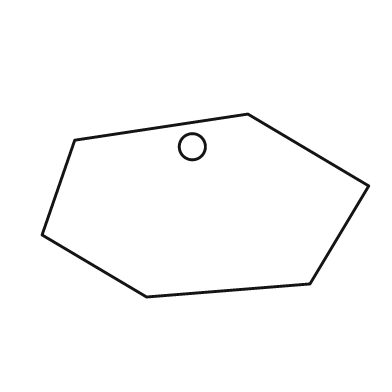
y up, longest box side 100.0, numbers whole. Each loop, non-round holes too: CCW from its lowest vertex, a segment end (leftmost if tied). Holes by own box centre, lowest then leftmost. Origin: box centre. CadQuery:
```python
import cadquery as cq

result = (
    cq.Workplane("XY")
    .moveTo(-18.0, -28.0)
    .lineTo(32.0, -24.0)
    .lineTo(50.0, 6.0)
    .lineTo(13.0, 28.0)
    .lineTo(-40.0, 20.0)
    .lineTo(-50.0, -9.0)
    .close()
    .moveTo(-4.0, 18.0)
    .circle(4.0)
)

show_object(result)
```